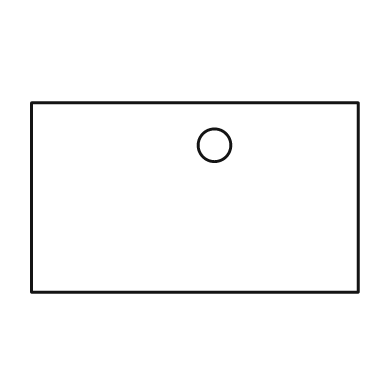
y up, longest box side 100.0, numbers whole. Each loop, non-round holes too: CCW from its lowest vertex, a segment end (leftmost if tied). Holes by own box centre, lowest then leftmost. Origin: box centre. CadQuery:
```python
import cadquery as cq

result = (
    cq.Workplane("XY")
    .moveTo(-50.0, -29.0)
    .lineTo(50.0, -29.0)
    .lineTo(50.0, 29.0)
    .lineTo(-50.0, 29.0)
    .close()
    .moveTo(6.0, 16.0)
    .circle(5.0)
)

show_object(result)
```